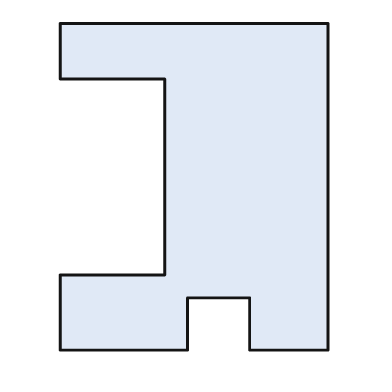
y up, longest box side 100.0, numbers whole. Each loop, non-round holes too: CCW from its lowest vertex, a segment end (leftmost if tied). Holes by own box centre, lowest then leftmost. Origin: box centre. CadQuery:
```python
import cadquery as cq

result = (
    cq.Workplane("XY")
    .moveTo(-41.0, -50.0)
    .lineTo(-2.0, -50.0)
    .lineTo(-2.0, -34.0)
    .lineTo(17.0, -34.0)
    .lineTo(17.0, -50.0)
    .lineTo(41.0, -50.0)
    .lineTo(41.0, 50.0)
    .lineTo(-41.0, 50.0)
    .lineTo(-41.0, 33.0)
    .lineTo(-9.0, 33.0)
    .lineTo(-9.0, -27.0)
    .lineTo(-41.0, -27.0)
    .close()
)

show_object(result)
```